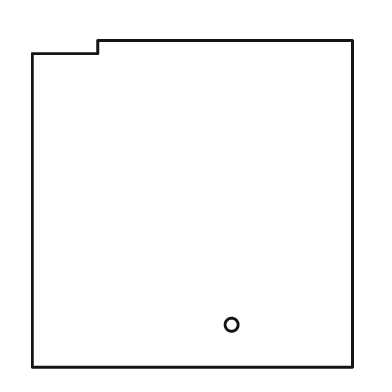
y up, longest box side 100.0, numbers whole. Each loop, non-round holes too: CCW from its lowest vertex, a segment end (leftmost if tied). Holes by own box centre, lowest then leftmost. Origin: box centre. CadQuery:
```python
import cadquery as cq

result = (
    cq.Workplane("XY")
    .moveTo(-49.0, -50.0)
    .lineTo(49.0, -50.0)
    .lineTo(49.0, 50.0)
    .lineTo(-29.0, 50.0)
    .lineTo(-29.0, 46.0)
    .lineTo(-49.0, 46.0)
    .close()
    .moveTo(12.0, -37.0)
    .circle(2.0)
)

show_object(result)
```